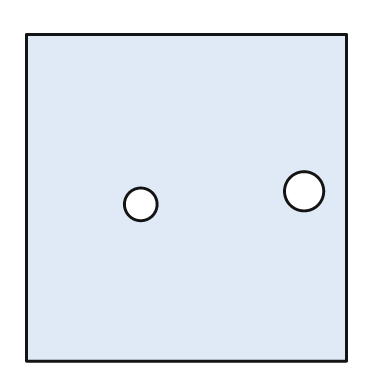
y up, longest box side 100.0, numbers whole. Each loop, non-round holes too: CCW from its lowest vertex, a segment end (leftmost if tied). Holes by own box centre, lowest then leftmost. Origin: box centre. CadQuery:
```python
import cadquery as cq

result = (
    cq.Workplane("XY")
    .moveTo(-49.0, -50.0)
    .lineTo(49.0, -50.0)
    .lineTo(49.0, 50.0)
    .lineTo(-49.0, 50.0)
    .close()
    .moveTo(-14.0, -2.0)
    .circle(5.0)
    .moveTo(36.0, 2.0)
    .circle(6.0)
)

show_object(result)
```